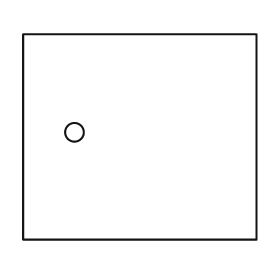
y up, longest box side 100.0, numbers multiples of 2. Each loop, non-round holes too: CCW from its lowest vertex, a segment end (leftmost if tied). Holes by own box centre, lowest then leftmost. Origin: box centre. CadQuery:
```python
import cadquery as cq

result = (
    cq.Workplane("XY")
    .moveTo(-50.0, -44.0)
    .lineTo(50.0, -44.0)
    .lineTo(50.0, 44.0)
    .lineTo(-50.0, 44.0)
    .close()
    .moveTo(-28.0, 2.0)
    .circle(4.0)
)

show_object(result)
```